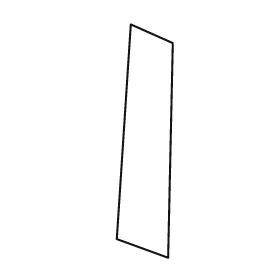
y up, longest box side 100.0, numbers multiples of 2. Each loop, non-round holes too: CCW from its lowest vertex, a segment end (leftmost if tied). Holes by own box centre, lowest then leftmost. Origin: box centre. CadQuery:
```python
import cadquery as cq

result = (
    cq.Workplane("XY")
    .moveTo(10.0, -50.0)
    .lineTo(12.0, 42.0)
    .lineTo(-6.0, 50.0)
    .lineTo(-12.0, -42.0)
    .close()
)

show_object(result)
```